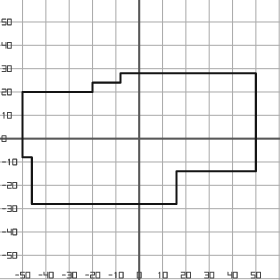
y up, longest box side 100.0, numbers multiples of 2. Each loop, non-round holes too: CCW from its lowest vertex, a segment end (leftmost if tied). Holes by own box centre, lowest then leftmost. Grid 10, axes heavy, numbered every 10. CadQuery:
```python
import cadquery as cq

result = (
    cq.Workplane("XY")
    .moveTo(-46.0, -28.0)
    .lineTo(16.0, -28.0)
    .lineTo(16.0, -14.0)
    .lineTo(50.0, -14.0)
    .lineTo(50.0, 28.0)
    .lineTo(-8.0, 28.0)
    .lineTo(-8.0, 24.0)
    .lineTo(-20.0, 24.0)
    .lineTo(-20.0, 20.0)
    .lineTo(-50.0, 20.0)
    .lineTo(-50.0, -8.0)
    .lineTo(-46.0, -8.0)
    .close()
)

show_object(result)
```